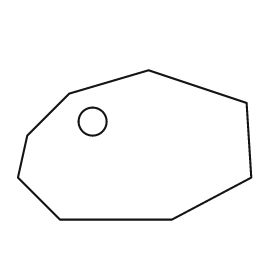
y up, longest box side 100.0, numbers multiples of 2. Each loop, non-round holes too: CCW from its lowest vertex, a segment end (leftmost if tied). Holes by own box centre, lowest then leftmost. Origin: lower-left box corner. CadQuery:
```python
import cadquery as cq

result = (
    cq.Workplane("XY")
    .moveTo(18.0, 0.0)
    .lineTo(66.0, 0.0)
    .lineTo(100.0, 18.0)
    .lineTo(98.0, 50.0)
    .lineTo(56.0, 64.0)
    .lineTo(22.0, 54.0)
    .lineTo(4.0, 36.0)
    .lineTo(0.0, 18.0)
    .close()
    .moveTo(32.0, 42.0)
    .circle(6.0)
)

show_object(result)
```